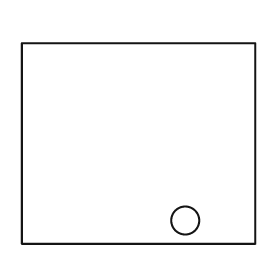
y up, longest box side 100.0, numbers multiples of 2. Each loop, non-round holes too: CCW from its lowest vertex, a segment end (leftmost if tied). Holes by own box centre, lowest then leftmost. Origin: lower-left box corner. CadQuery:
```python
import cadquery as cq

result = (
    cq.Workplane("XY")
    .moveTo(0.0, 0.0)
    .lineTo(100.0, 0.0)
    .lineTo(100.0, 86.0)
    .lineTo(0.0, 86.0)
    .close()
    .moveTo(70.0, 10.0)
    .circle(6.0)
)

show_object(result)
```